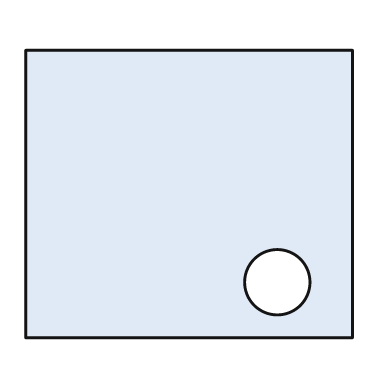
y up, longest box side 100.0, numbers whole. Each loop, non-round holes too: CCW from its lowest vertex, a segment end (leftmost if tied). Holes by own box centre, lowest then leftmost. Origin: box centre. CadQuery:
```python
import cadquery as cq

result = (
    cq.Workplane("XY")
    .moveTo(-50.0, -44.0)
    .lineTo(50.0, -44.0)
    .lineTo(50.0, 44.0)
    .lineTo(-50.0, 44.0)
    .close()
    .moveTo(27.0, -27.0)
    .circle(10.0)
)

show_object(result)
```